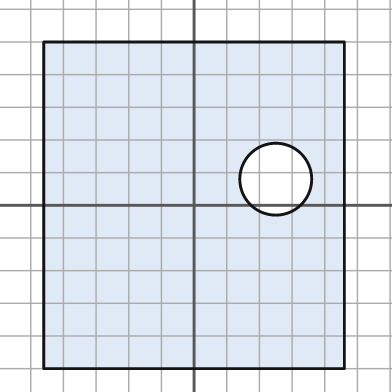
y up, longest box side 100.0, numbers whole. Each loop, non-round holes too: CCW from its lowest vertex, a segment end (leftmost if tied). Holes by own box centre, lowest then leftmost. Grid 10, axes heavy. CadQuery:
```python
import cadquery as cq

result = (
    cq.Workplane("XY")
    .moveTo(-46.0, -50.0)
    .lineTo(46.0, -50.0)
    .lineTo(46.0, 50.0)
    .lineTo(-46.0, 50.0)
    .close()
    .moveTo(25.0, 8.0)
    .circle(11.0)
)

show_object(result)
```